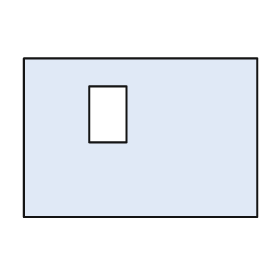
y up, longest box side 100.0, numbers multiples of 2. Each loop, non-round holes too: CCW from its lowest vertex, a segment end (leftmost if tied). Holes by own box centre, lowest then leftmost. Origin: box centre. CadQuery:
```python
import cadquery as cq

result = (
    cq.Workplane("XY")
    .moveTo(-50.0, -34.0)
    .lineTo(50.0, -34.0)
    .lineTo(50.0, 34.0)
    .lineTo(-50.0, 34.0)
    .close()
    .moveTo(-22.0, -2.0)
    .lineTo(-6.0, -2.0)
    .lineTo(-6.0, 22.0)
    .lineTo(-22.0, 22.0)
    .close()
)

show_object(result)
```